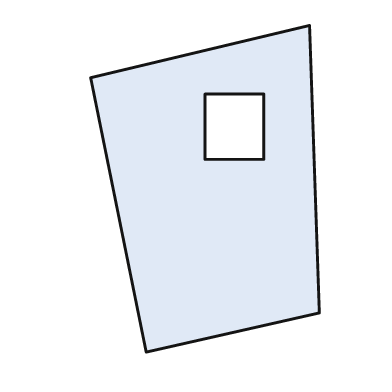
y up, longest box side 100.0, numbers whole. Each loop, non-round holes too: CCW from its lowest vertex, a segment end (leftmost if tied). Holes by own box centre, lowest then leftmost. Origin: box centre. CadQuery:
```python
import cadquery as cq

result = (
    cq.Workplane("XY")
    .moveTo(-18.0, -50.0)
    .lineTo(35.0, -38.0)
    .lineTo(32.0, 50.0)
    .lineTo(-35.0, 34.0)
    .close()
    .moveTo(0.0, 9.0)
    .lineTo(18.0, 9.0)
    .lineTo(18.0, 29.0)
    .lineTo(0.0, 29.0)
    .close()
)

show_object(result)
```